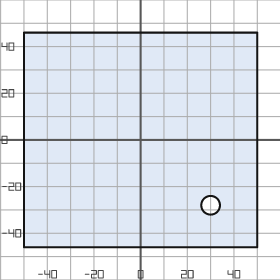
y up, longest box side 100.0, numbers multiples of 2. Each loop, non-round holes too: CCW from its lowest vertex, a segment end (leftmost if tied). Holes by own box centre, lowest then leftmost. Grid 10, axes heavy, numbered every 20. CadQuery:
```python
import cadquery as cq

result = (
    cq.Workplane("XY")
    .moveTo(-50.0, -46.0)
    .lineTo(50.0, -46.0)
    .lineTo(50.0, 46.0)
    .lineTo(-50.0, 46.0)
    .close()
    .moveTo(30.0, -28.0)
    .circle(4.0)
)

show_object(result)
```